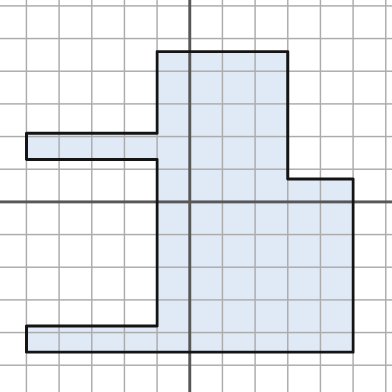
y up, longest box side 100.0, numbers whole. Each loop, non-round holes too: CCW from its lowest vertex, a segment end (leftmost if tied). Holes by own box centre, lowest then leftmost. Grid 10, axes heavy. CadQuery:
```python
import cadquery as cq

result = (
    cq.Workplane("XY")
    .moveTo(-50.0, -46.0)
    .lineTo(50.0, -46.0)
    .lineTo(50.0, 7.0)
    .lineTo(30.0, 7.0)
    .lineTo(30.0, 46.0)
    .lineTo(-10.0, 46.0)
    .lineTo(-10.0, 21.0)
    .lineTo(-50.0, 21.0)
    .lineTo(-50.0, 13.0)
    .lineTo(-10.0, 13.0)
    .lineTo(-10.0, -38.0)
    .lineTo(-50.0, -38.0)
    .close()
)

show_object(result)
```